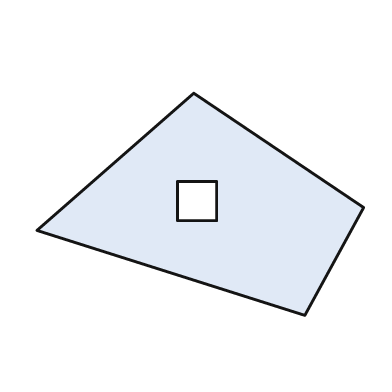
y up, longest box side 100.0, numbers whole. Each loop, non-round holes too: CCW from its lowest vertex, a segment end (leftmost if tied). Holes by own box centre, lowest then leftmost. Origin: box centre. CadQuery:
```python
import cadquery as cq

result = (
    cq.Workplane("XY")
    .moveTo(32.0, -34.0)
    .lineTo(50.0, -1.0)
    .lineTo(-2.0, 34.0)
    .lineTo(-50.0, -8.0)
    .close()
    .moveTo(-7.0, -5.0)
    .lineTo(5.0, -5.0)
    .lineTo(5.0, 7.0)
    .lineTo(-7.0, 7.0)
    .close()
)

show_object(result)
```